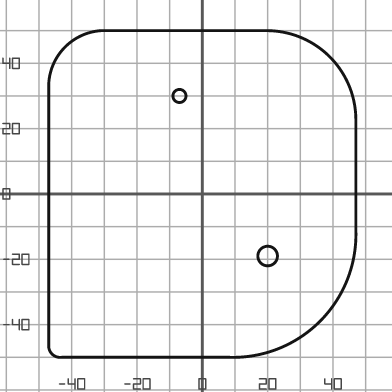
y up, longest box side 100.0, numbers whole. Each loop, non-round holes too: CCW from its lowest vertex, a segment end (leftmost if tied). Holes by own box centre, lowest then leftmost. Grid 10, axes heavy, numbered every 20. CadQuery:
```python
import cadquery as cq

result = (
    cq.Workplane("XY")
    .moveTo(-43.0, -50.0)
    .lineTo(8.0, -50.0)
    .threePointArc((36.0, -39.0), (47.0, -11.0))
    .lineTo(47.0, 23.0)
    .threePointArc((39.0, 42.0), (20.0, 50.0))
    .lineTo(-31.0, 50.0)
    .threePointArc((-42.0, 45.0), (-47.0, 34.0))
    .lineTo(-47.0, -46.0)
    .threePointArc((-46.0, -49.0), (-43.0, -50.0))
    .close()
    .moveTo(20.0, -19.0)
    .circle(3.0)
    .moveTo(-7.0, 30.0)
    .circle(2.0)
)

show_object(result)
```